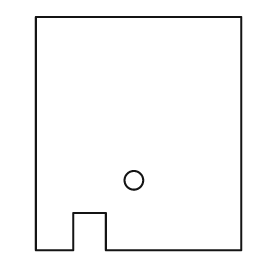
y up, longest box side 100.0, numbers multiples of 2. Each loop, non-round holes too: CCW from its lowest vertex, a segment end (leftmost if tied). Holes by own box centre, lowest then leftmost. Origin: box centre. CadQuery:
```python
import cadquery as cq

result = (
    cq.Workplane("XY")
    .moveTo(-44.0, -50.0)
    .lineTo(-28.0, -50.0)
    .lineTo(-28.0, -34.0)
    .lineTo(-14.0, -34.0)
    .lineTo(-14.0, -50.0)
    .lineTo(44.0, -50.0)
    .lineTo(44.0, 50.0)
    .lineTo(-44.0, 50.0)
    .close()
    .moveTo(-2.0, -20.0)
    .circle(4.0)
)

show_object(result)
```